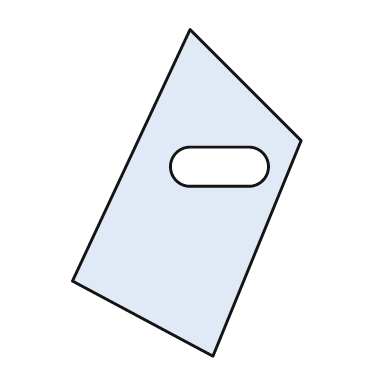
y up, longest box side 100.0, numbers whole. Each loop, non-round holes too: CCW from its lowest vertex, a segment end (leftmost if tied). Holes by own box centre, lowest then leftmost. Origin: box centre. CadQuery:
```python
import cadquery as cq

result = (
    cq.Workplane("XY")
    .moveTo(8.0, -50.0)
    .lineTo(35.0, 16.0)
    .lineTo(1.0, 50.0)
    .lineTo(-35.0, -27.0)
    .close()
    .moveTo(1.0, 2.0)
    .lineTo(19.0, 2.0)
    .threePointArc((25.0, 8.0), (19.0, 14.0))
    .lineTo(1.0, 14.0)
    .threePointArc((-5.0, 8.0), (1.0, 2.0))
    .close()
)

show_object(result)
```